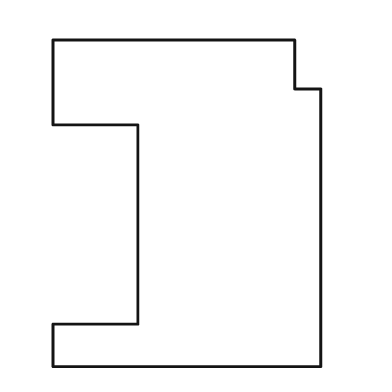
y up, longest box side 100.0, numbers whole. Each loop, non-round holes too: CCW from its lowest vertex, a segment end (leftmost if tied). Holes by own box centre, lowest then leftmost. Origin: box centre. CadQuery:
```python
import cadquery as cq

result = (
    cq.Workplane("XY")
    .moveTo(-41.0, -50.0)
    .lineTo(41.0, -50.0)
    .lineTo(41.0, 35.0)
    .lineTo(33.0, 35.0)
    .lineTo(33.0, 50.0)
    .lineTo(-41.0, 50.0)
    .lineTo(-41.0, 24.0)
    .lineTo(-15.0, 24.0)
    .lineTo(-15.0, -37.0)
    .lineTo(-41.0, -37.0)
    .close()
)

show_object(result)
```